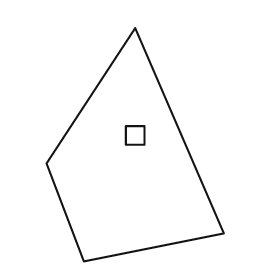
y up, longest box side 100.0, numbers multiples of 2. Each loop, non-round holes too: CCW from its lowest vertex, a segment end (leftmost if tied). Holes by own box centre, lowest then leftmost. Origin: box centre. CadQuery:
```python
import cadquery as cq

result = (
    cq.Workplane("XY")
    .moveTo(-22.0, -50.0)
    .lineTo(38.0, -38.0)
    .lineTo(0.0, 50.0)
    .lineTo(-38.0, -8.0)
    .close()
    .moveTo(-4.0, 0.0)
    .lineTo(4.0, 0.0)
    .lineTo(4.0, 8.0)
    .lineTo(-4.0, 8.0)
    .close()
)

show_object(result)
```